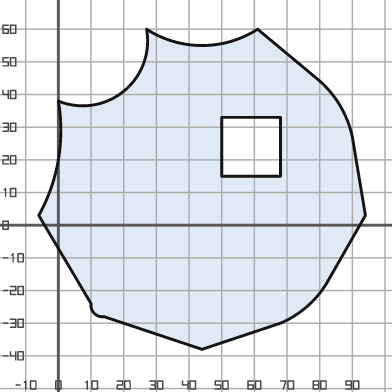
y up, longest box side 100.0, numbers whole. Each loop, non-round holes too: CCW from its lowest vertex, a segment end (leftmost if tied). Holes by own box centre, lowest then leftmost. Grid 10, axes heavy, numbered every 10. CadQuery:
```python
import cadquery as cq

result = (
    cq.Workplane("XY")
    .moveTo(44.0, -38.0)
    .lineTo(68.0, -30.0)
    .threePointArc((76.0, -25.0), (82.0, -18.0))
    .lineTo(94.0, 3.0)
    .lineTo(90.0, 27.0)
    .threePointArc((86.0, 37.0), (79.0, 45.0))
    .lineTo(61.0, 60.0)
    .threePointArc((44.0, 55.0), (27.0, 60.0))
    .threePointArc((20.0, 41.0), (0.0, 38.0))
    .threePointArc((0.0, 20.0), (-6.0, 3.0))
    .lineTo(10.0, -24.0)
    .threePointArc((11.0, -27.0), (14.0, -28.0))
    .close()
    .moveTo(50.0, 15.0)
    .lineTo(68.0, 15.0)
    .lineTo(68.0, 33.0)
    .lineTo(50.0, 33.0)
    .close()
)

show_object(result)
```